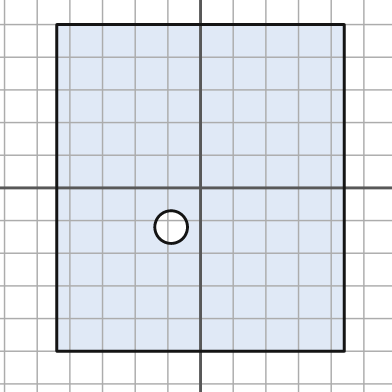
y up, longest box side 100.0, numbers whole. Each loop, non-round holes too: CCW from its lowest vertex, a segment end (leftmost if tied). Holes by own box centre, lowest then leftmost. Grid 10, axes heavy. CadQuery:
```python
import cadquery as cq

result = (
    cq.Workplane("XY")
    .moveTo(-44.0, -50.0)
    .lineTo(44.0, -50.0)
    .lineTo(44.0, 50.0)
    .lineTo(-44.0, 50.0)
    .close()
    .moveTo(-9.0, -12.0)
    .circle(5.0)
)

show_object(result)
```